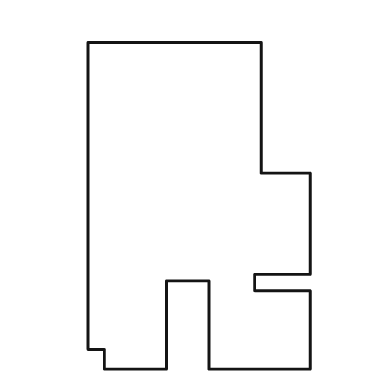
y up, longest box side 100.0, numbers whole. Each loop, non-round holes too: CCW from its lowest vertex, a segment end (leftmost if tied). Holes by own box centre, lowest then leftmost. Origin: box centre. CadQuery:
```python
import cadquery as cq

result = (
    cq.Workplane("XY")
    .moveTo(-29.0, -50.0)
    .lineTo(-10.0, -50.0)
    .lineTo(-10.0, -23.0)
    .lineTo(3.0, -23.0)
    .lineTo(3.0, -50.0)
    .lineTo(34.0, -50.0)
    .lineTo(34.0, -26.0)
    .lineTo(17.0, -26.0)
    .lineTo(17.0, -21.0)
    .lineTo(34.0, -21.0)
    .lineTo(34.0, 10.0)
    .lineTo(19.0, 10.0)
    .lineTo(19.0, 50.0)
    .lineTo(-34.0, 50.0)
    .lineTo(-34.0, -44.0)
    .lineTo(-29.0, -44.0)
    .close()
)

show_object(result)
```